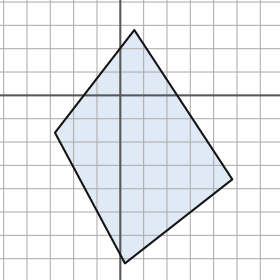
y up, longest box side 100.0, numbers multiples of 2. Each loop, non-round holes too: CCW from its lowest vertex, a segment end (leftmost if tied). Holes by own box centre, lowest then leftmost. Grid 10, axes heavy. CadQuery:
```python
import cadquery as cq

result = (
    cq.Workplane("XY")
    .moveTo(2.0, -72.0)
    .lineTo(48.0, -36.0)
    .lineTo(6.0, 28.0)
    .lineTo(-28.0, -16.0)
    .close()
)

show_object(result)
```